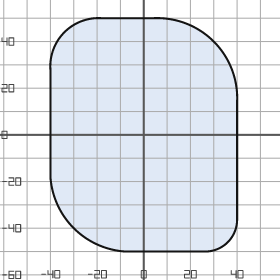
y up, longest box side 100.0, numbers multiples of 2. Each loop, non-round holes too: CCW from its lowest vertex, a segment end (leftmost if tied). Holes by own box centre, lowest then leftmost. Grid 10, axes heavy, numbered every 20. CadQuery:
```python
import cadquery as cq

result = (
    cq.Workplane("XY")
    .moveTo(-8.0, -50.0)
    .lineTo(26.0, -50.0)
    .threePointArc((36.0, -46.0), (40.0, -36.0))
    .lineTo(40.0, 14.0)
    .threePointArc((30.0, 40.0), (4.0, 50.0))
    .lineTo(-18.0, 50.0)
    .threePointArc((-34.0, 44.0), (-40.0, 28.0))
    .lineTo(-40.0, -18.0)
    .threePointArc((-30.0, -40.0), (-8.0, -50.0))
    .close()
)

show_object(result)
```